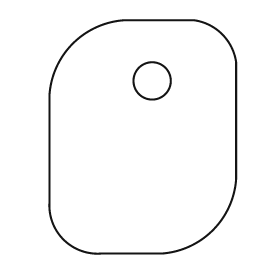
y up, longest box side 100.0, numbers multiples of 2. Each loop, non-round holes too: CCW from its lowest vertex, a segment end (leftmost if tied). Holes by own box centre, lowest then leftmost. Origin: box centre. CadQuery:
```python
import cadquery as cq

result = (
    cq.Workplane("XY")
    .moveTo(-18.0, -50.0)
    .lineTo(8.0, -50.0)
    .threePointArc((30.0, -40.0), (40.0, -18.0))
    .lineTo(40.0, 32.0)
    .threePointArc((34.0, 44.0), (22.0, 50.0))
    .lineTo(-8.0, 50.0)
    .threePointArc((-30.0, 40.0), (-40.0, 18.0))
    .lineTo(-40.0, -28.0)
    .threePointArc((-34.0, -44.0), (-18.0, -50.0))
    .close()
    .moveTo(4.0, 24.0)
    .circle(8.0)
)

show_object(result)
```